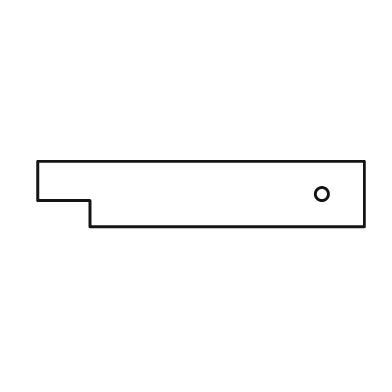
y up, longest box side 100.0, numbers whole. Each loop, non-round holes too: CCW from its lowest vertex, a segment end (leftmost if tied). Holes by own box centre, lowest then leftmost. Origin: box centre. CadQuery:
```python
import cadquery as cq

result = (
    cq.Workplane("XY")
    .moveTo(-34.0, -10.0)
    .lineTo(50.0, -10.0)
    .lineTo(50.0, 10.0)
    .lineTo(-50.0, 10.0)
    .lineTo(-50.0, -2.0)
    .lineTo(-34.0, -2.0)
    .close()
    .moveTo(37.0, 0.0)
    .circle(2.0)
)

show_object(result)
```